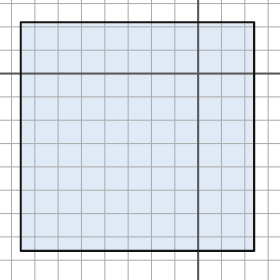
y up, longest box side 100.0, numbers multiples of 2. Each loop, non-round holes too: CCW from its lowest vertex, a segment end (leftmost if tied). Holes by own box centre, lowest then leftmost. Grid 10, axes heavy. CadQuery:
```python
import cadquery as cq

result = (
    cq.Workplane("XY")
    .moveTo(-76.0, -76.0)
    .lineTo(24.0, -76.0)
    .lineTo(24.0, 22.0)
    .lineTo(-76.0, 22.0)
    .close()
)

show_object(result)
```